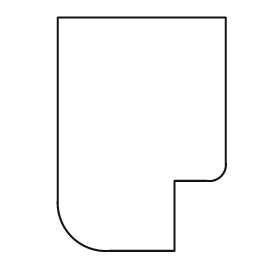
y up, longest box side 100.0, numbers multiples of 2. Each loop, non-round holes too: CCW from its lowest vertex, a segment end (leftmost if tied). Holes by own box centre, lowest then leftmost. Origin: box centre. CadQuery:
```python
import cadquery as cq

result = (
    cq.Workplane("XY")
    .moveTo(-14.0, -50.0)
    .lineTo(14.0, -50.0)
    .lineTo(14.0, -20.0)
    .lineTo(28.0, -20.0)
    .threePointArc((34.0, -18.0), (36.0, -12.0))
    .lineTo(36.0, 50.0)
    .lineTo(-36.0, 50.0)
    .lineTo(-36.0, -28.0)
    .threePointArc((-30.0, -44.0), (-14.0, -50.0))
    .close()
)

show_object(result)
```